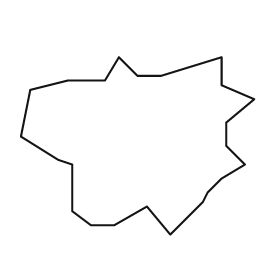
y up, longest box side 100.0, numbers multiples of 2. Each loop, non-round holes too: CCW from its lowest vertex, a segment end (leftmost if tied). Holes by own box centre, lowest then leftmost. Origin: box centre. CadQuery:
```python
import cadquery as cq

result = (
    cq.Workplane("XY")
    .moveTo(14.0, -38.0)
    .lineTo(28.0, -24.0)
    .lineTo(30.0, -20.0)
    .lineTo(36.0, -14.0)
    .lineTo(46.0, -8.0)
    .lineTo(38.0, 0.0)
    .lineTo(38.0, 10.0)
    .lineTo(50.0, 20.0)
    .lineTo(36.0, 26.0)
    .lineTo(36.0, 38.0)
    .lineTo(10.0, 30.0)
    .lineTo(0.0, 30.0)
    .lineTo(-8.0, 38.0)
    .lineTo(-14.0, 28.0)
    .lineTo(-30.0, 28.0)
    .lineTo(-46.0, 24.0)
    .lineTo(-50.0, 4.0)
    .lineTo(-34.0, -6.0)
    .lineTo(-28.0, -8.0)
    .lineTo(-28.0, -28.0)
    .lineTo(-20.0, -34.0)
    .lineTo(-10.0, -34.0)
    .lineTo(4.0, -26.0)
    .close()
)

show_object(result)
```